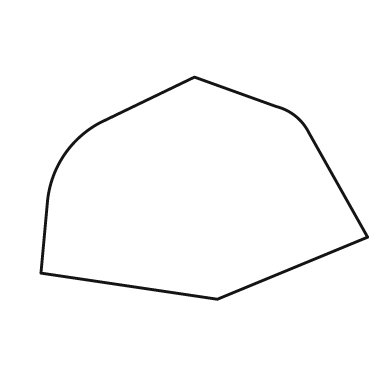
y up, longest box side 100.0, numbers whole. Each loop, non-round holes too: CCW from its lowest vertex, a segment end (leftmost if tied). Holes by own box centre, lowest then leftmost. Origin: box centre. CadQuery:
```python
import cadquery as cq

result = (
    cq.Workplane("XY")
    .moveTo(4.0, -34.0)
    .lineTo(50.0, -15.0)
    .lineTo(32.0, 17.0)
    .threePointArc((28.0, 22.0), (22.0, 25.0))
    .lineTo(-3.0, 34.0)
    .lineTo(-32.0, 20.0)
    .threePointArc((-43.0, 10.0), (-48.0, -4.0))
    .lineTo(-50.0, -26.0)
    .close()
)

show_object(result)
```